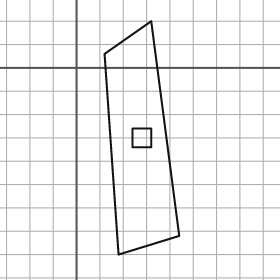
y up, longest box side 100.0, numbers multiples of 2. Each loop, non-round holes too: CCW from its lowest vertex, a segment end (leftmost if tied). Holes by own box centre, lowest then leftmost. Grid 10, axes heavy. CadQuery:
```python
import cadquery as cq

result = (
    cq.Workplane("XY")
    .moveTo(18.0, -80.0)
    .lineTo(44.0, -72.0)
    .lineTo(32.0, 20.0)
    .lineTo(12.0, 6.0)
    .close()
    .moveTo(24.0, -34.0)
    .lineTo(32.0, -34.0)
    .lineTo(32.0, -26.0)
    .lineTo(24.0, -26.0)
    .close()
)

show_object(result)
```